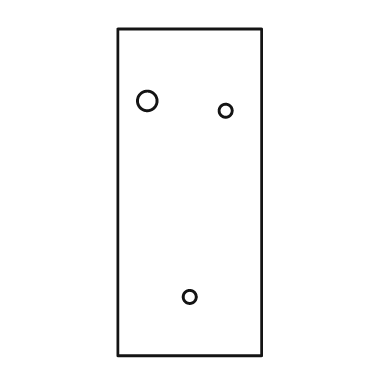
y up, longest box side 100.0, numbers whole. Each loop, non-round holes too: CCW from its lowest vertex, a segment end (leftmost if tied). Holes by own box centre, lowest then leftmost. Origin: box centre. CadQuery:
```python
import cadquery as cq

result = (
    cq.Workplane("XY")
    .moveTo(-22.0, -50.0)
    .lineTo(22.0, -50.0)
    .lineTo(22.0, 50.0)
    .lineTo(-22.0, 50.0)
    .close()
    .moveTo(0.0, -32.0)
    .circle(2.0)
    .moveTo(11.0, 25.0)
    .circle(2.0)
    .moveTo(-13.0, 28.0)
    .circle(3.0)
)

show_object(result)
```